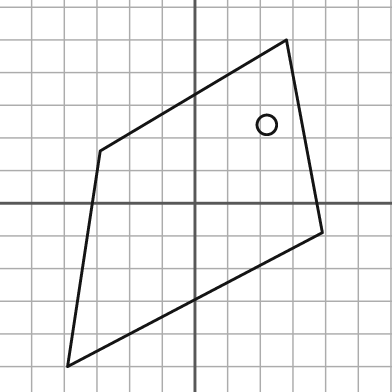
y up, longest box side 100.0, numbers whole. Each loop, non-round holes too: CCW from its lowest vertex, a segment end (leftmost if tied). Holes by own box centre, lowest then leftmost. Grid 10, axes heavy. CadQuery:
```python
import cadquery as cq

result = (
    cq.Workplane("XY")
    .moveTo(-39.0, -50.0)
    .lineTo(39.0, -9.0)
    .lineTo(28.0, 50.0)
    .lineTo(-29.0, 16.0)
    .close()
    .moveTo(22.0, 24.0)
    .circle(3.0)
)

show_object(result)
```